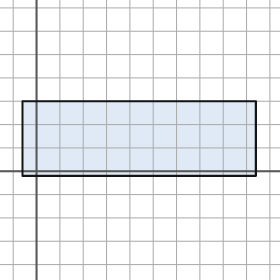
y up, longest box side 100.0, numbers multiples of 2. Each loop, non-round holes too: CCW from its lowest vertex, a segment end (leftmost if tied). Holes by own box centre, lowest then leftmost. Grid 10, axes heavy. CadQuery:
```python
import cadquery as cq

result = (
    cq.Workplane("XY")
    .moveTo(-6.0, -2.0)
    .lineTo(94.0, -2.0)
    .lineTo(94.0, 30.0)
    .lineTo(-6.0, 30.0)
    .close()
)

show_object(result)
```